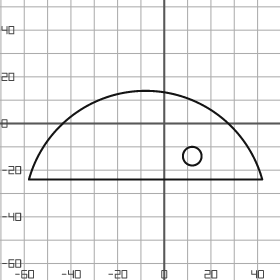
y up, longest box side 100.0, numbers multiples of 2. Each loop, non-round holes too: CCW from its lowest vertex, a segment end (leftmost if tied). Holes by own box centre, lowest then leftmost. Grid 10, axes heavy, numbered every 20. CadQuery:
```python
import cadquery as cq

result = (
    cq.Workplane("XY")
    .moveTo(-58.0, -24.0)
    .lineTo(42.0, -24.0)
    .threePointArc((-8.0, 14.0), (-58.0, -24.0))
    .close()
    .moveTo(12.0, -14.0)
    .circle(4.0)
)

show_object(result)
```